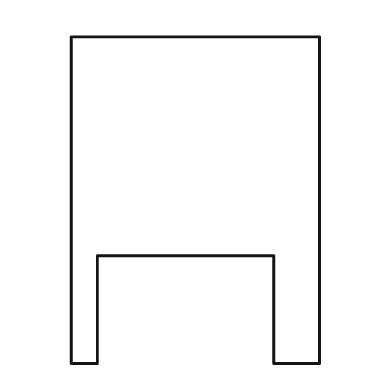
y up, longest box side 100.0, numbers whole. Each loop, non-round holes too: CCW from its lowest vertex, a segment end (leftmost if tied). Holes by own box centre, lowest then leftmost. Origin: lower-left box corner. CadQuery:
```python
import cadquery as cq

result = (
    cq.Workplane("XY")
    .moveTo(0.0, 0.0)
    .lineTo(8.0, 0.0)
    .lineTo(8.0, 33.0)
    .lineTo(62.0, 33.0)
    .lineTo(62.0, 0.0)
    .lineTo(76.0, 0.0)
    .lineTo(76.0, 100.0)
    .lineTo(0.0, 100.0)
    .close()
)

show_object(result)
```